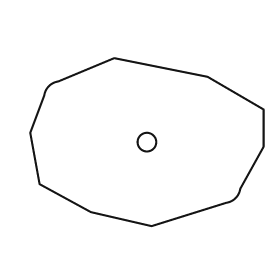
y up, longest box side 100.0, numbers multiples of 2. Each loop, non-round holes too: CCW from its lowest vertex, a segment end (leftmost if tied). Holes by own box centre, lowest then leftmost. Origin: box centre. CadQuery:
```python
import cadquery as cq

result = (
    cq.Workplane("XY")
    .moveTo(2.0, -36.0)
    .lineTo(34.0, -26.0)
    .threePointArc((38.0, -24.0), (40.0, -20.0))
    .lineTo(50.0, -2.0)
    .lineTo(50.0, 14.0)
    .lineTo(26.0, 28.0)
    .lineTo(-14.0, 36.0)
    .lineTo(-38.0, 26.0)
    .threePointArc((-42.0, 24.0), (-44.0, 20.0))
    .lineTo(-50.0, 4.0)
    .lineTo(-46.0, -18.0)
    .lineTo(-24.0, -30.0)
    .close()
    .moveTo(0.0, 0.0)
    .circle(4.0)
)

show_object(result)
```